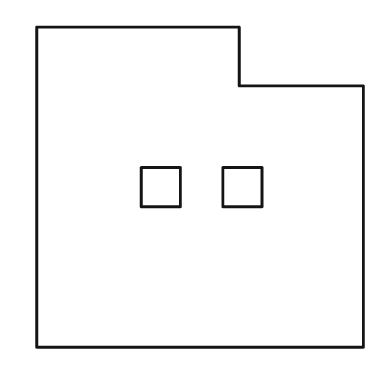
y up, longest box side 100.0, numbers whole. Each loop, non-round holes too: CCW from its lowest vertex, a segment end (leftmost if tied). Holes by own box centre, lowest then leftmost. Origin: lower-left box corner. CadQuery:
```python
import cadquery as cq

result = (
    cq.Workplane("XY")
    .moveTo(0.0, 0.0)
    .lineTo(100.0, 0.0)
    .lineTo(100.0, 80.0)
    .lineTo(62.0, 80.0)
    .lineTo(62.0, 98.0)
    .lineTo(0.0, 98.0)
    .close()
    .moveTo(32.0, 43.0)
    .lineTo(44.0, 43.0)
    .lineTo(44.0, 55.0)
    .lineTo(32.0, 55.0)
    .close()
    .moveTo(57.0, 43.0)
    .lineTo(69.0, 43.0)
    .lineTo(69.0, 55.0)
    .lineTo(57.0, 55.0)
    .close()
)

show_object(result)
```